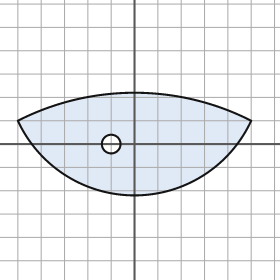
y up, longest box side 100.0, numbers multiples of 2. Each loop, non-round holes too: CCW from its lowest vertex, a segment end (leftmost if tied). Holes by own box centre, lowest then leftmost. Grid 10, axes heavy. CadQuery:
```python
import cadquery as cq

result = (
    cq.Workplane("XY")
    .moveTo(-50.0, 10.0)
    .threePointArc((0.0, -22.0), (50.0, 10.0))
    .threePointArc((0.0, 22.0), (-50.0, 10.0))
    .close()
    .moveTo(-10.0, 0.0)
    .circle(4.0)
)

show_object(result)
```